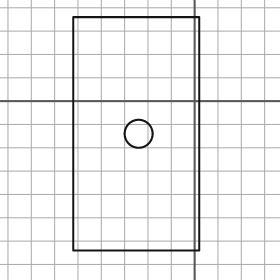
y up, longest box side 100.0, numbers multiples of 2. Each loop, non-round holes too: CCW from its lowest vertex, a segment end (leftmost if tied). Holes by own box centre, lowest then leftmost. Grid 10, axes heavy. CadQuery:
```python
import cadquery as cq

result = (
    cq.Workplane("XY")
    .moveTo(-52.0, -64.0)
    .lineTo(2.0, -64.0)
    .lineTo(2.0, 36.0)
    .lineTo(-52.0, 36.0)
    .close()
    .moveTo(-24.0, -14.0)
    .circle(6.0)
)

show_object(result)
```